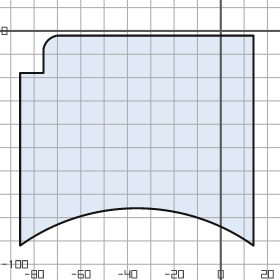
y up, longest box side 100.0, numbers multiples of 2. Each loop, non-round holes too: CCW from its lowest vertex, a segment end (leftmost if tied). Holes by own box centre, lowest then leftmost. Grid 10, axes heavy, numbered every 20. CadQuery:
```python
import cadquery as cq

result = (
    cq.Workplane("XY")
    .moveTo(-86.0, -92.0)
    .threePointArc((-36.0, -76.0), (14.0, -92.0))
    .lineTo(14.0, -2.0)
    .lineTo(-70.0, -2.0)
    .threePointArc((-74.0, -4.0), (-76.0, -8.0))
    .lineTo(-76.0, -18.0)
    .lineTo(-86.0, -18.0)
    .close()
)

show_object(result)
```